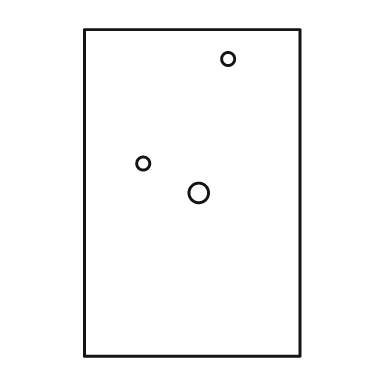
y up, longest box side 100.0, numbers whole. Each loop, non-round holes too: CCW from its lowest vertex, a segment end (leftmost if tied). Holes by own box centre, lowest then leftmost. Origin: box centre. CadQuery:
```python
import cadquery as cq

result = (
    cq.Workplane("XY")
    .moveTo(-33.0, -50.0)
    .lineTo(33.0, -50.0)
    .lineTo(33.0, 50.0)
    .lineTo(-33.0, 50.0)
    .close()
    .moveTo(2.0, 0.0)
    .circle(3.0)
    .moveTo(-15.0, 9.0)
    .circle(2.0)
    .moveTo(11.0, 41.0)
    .circle(2.0)
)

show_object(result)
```